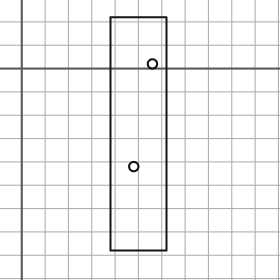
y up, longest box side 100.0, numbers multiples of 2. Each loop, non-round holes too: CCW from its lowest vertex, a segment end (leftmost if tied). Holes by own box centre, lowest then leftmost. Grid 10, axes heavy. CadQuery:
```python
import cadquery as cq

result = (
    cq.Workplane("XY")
    .moveTo(38.0, -78.0)
    .lineTo(62.0, -78.0)
    .lineTo(62.0, 22.0)
    .lineTo(38.0, 22.0)
    .close()
    .moveTo(48.0, -42.0)
    .circle(2.0)
    .moveTo(56.0, 2.0)
    .circle(2.0)
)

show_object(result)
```